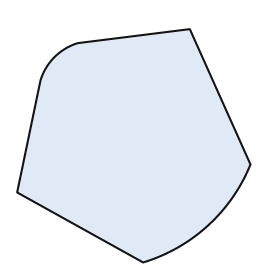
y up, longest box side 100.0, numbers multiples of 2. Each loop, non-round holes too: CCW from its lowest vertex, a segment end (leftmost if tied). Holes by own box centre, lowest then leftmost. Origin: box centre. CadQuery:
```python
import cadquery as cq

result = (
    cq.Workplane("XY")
    .moveTo(4.0, -50.0)
    .threePointArc((32.0, -34.0), (50.0, -8.0))
    .lineTo(24.0, 50.0)
    .lineTo(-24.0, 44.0)
    .threePointArc((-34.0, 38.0), (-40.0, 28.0))
    .lineTo(-50.0, -20.0)
    .close()
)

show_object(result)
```